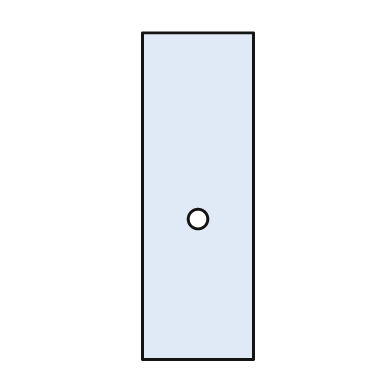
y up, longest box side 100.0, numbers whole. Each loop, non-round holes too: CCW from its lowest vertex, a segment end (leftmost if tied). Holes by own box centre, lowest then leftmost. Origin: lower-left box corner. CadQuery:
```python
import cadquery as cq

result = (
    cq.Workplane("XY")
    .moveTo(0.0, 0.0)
    .lineTo(34.0, 0.0)
    .lineTo(34.0, 100.0)
    .lineTo(0.0, 100.0)
    .close()
    .moveTo(17.0, 43.0)
    .circle(3.0)
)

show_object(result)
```